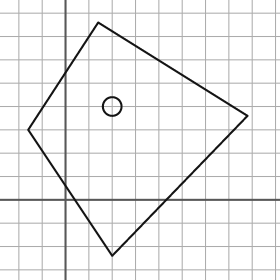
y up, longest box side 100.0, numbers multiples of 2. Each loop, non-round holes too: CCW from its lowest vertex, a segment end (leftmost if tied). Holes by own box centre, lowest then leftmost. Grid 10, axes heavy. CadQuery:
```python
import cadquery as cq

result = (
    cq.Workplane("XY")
    .moveTo(20.0, -24.0)
    .lineTo(78.0, 36.0)
    .lineTo(14.0, 76.0)
    .lineTo(-16.0, 30.0)
    .close()
    .moveTo(20.0, 40.0)
    .circle(4.0)
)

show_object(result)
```